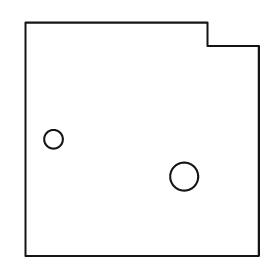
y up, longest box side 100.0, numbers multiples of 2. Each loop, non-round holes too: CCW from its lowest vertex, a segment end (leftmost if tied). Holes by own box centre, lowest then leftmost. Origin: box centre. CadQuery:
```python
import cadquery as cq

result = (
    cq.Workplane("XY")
    .moveTo(-50.0, -50.0)
    .lineTo(50.0, -50.0)
    .lineTo(50.0, 40.0)
    .lineTo(28.0, 40.0)
    .lineTo(28.0, 50.0)
    .lineTo(-50.0, 50.0)
    .close()
    .moveTo(18.0, -16.0)
    .circle(6.0)
    .moveTo(-38.0, 0.0)
    .circle(4.0)
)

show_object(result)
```